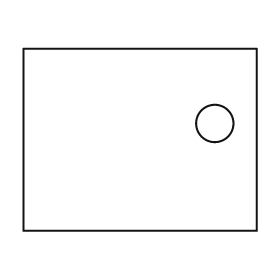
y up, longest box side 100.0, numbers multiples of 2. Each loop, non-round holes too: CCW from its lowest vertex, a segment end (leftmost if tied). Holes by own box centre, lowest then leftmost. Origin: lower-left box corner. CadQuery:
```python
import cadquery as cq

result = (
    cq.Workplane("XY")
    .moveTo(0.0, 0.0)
    .lineTo(100.0, 0.0)
    .lineTo(100.0, 78.0)
    .lineTo(0.0, 78.0)
    .close()
    .moveTo(82.0, 46.0)
    .circle(8.0)
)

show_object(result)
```